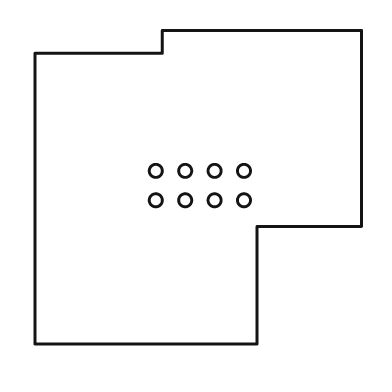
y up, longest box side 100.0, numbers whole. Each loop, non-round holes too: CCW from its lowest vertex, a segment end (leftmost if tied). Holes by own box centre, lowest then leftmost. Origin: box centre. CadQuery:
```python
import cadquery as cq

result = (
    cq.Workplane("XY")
    .moveTo(-50.0, -48.0)
    .lineTo(18.0, -48.0)
    .lineTo(18.0, -12.0)
    .lineTo(50.0, -12.0)
    .lineTo(50.0, 48.0)
    .lineTo(-11.0, 48.0)
    .lineTo(-11.0, 41.0)
    .lineTo(-50.0, 41.0)
    .close()
    .moveTo(-13.0, -4.0)
    .circle(2.0)
    .moveTo(-4.0, -4.0)
    .circle(2.0)
    .moveTo(5.0, -4.0)
    .circle(2.0)
    .moveTo(14.0, -4.0)
    .circle(2.0)
    .moveTo(-13.0, 5.0)
    .circle(2.0)
    .moveTo(-4.0, 5.0)
    .circle(2.0)
    .moveTo(5.0, 5.0)
    .circle(2.0)
    .moveTo(14.0, 5.0)
    .circle(2.0)
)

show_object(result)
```